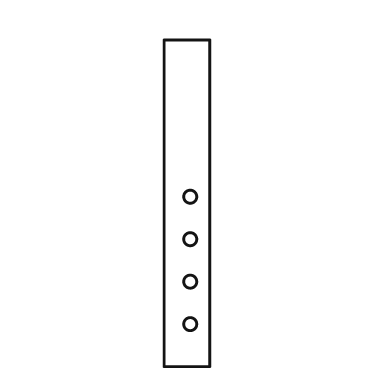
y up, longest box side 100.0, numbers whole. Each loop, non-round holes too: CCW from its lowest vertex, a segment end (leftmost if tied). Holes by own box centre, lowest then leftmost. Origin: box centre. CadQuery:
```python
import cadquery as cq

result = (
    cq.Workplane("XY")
    .moveTo(-7.0, -50.0)
    .lineTo(7.0, -50.0)
    .lineTo(7.0, 50.0)
    .lineTo(-7.0, 50.0)
    .close()
    .moveTo(1.0, -37.0)
    .circle(2.0)
    .moveTo(1.0, -24.0)
    .circle(2.0)
    .moveTo(1.0, -11.0)
    .circle(2.0)
    .moveTo(1.0, 2.0)
    .circle(2.0)
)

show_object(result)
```